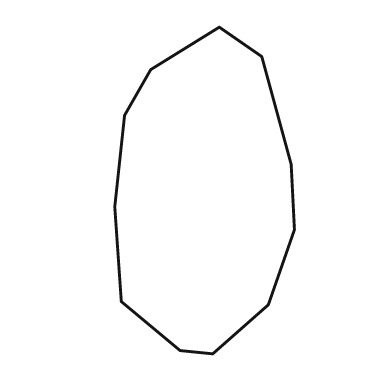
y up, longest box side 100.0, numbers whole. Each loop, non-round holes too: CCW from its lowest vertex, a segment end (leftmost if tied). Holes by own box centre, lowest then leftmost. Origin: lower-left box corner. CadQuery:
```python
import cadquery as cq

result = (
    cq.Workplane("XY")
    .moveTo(30.0, 0.0)
    .lineTo(47.0, 15.0)
    .lineTo(55.0, 38.0)
    .lineTo(54.0, 58.0)
    .lineTo(45.0, 91.0)
    .lineTo(32.0, 100.0)
    .lineTo(11.0, 87.0)
    .lineTo(3.0, 73.0)
    .lineTo(0.0, 45.0)
    .lineTo(2.0, 16.0)
    .lineTo(20.0, 1.0)
    .close()
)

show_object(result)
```